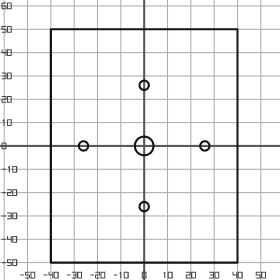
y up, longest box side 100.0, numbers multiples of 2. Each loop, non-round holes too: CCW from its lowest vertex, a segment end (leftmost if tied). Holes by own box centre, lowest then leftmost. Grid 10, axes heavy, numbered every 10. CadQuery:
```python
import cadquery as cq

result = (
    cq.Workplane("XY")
    .moveTo(-40.0, -50.0)
    .lineTo(40.0, -50.0)
    .lineTo(40.0, 50.0)
    .lineTo(-40.0, 50.0)
    .close()
    .moveTo(0.0, -26.0)
    .circle(2.0)
    .moveTo(-26.0, 0.0)
    .circle(2.0)
    .moveTo(0.0, 0.0)
    .circle(4.0)
    .moveTo(26.0, 0.0)
    .circle(2.0)
    .moveTo(0.0, 26.0)
    .circle(2.0)
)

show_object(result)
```